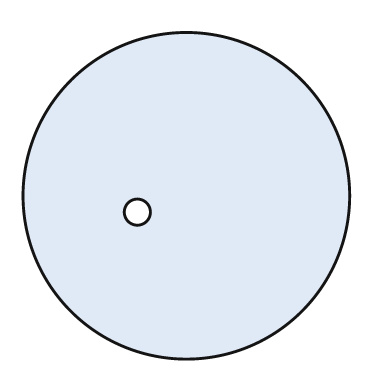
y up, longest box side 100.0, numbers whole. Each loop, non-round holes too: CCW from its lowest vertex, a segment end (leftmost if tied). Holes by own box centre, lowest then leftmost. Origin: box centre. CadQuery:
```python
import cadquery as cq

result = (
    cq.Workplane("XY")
    .moveTo(0.0, 0.0)
    .circle(50.0)
    .moveTo(-15.0, -5.0)
    .circle(4.0)
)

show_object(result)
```